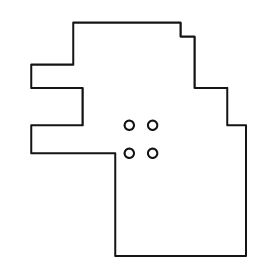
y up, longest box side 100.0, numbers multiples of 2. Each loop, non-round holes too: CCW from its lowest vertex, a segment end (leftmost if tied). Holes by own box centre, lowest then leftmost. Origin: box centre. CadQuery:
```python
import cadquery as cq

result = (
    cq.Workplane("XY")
    .moveTo(-10.0, -50.0)
    .lineTo(46.0, -50.0)
    .lineTo(46.0, 6.0)
    .lineTo(38.0, 6.0)
    .lineTo(38.0, 22.0)
    .lineTo(24.0, 22.0)
    .lineTo(24.0, 44.0)
    .lineTo(18.0, 44.0)
    .lineTo(18.0, 50.0)
    .lineTo(-28.0, 50.0)
    .lineTo(-28.0, 32.0)
    .lineTo(-46.0, 32.0)
    .lineTo(-46.0, 22.0)
    .lineTo(-24.0, 22.0)
    .lineTo(-24.0, 6.0)
    .lineTo(-46.0, 6.0)
    .lineTo(-46.0, -6.0)
    .lineTo(-10.0, -6.0)
    .close()
    .moveTo(-4.0, -6.0)
    .circle(2.0)
    .moveTo(6.0, -6.0)
    .circle(2.0)
    .moveTo(-4.0, 6.0)
    .circle(2.0)
    .moveTo(6.0, 6.0)
    .circle(2.0)
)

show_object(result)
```